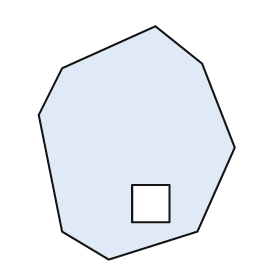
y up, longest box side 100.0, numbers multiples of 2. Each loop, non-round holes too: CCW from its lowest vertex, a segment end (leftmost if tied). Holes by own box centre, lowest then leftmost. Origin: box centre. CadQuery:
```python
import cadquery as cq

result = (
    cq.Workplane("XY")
    .moveTo(-12.0, -50.0)
    .lineTo(26.0, -38.0)
    .lineTo(42.0, -2.0)
    .lineTo(28.0, 34.0)
    .lineTo(8.0, 50.0)
    .lineTo(-32.0, 32.0)
    .lineTo(-42.0, 12.0)
    .lineTo(-32.0, -38.0)
    .close()
    .moveTo(-2.0, -34.0)
    .lineTo(14.0, -34.0)
    .lineTo(14.0, -18.0)
    .lineTo(-2.0, -18.0)
    .close()
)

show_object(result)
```